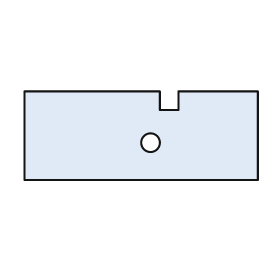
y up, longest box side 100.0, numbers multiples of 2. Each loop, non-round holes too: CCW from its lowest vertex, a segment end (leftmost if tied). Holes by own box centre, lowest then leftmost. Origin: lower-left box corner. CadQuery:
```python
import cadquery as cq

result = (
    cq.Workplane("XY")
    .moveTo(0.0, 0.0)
    .lineTo(100.0, 0.0)
    .lineTo(100.0, 38.0)
    .lineTo(66.0, 38.0)
    .lineTo(66.0, 30.0)
    .lineTo(58.0, 30.0)
    .lineTo(58.0, 38.0)
    .lineTo(0.0, 38.0)
    .close()
    .moveTo(54.0, 16.0)
    .circle(4.0)
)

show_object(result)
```